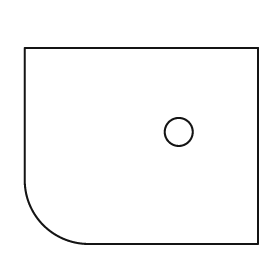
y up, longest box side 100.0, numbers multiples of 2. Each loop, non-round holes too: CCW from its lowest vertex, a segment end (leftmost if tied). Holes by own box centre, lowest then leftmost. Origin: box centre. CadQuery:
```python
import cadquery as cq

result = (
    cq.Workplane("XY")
    .moveTo(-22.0, -42.0)
    .lineTo(50.0, -42.0)
    .lineTo(50.0, 42.0)
    .lineTo(-50.0, 42.0)
    .lineTo(-50.0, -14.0)
    .threePointArc((-42.0, -34.0), (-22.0, -42.0))
    .close()
    .moveTo(16.0, 6.0)
    .circle(6.0)
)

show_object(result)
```